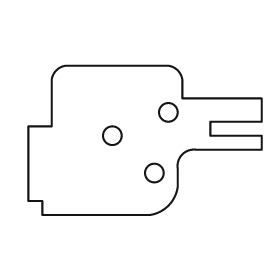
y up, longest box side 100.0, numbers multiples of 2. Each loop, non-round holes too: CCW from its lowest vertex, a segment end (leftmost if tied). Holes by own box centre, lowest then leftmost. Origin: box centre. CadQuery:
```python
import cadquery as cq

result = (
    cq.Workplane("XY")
    .moveTo(-44.0, -32.0)
    .lineTo(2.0, -32.0)
    .threePointArc((10.0, -28.0), (14.0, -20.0))
    .lineTo(14.0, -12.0)
    .threePointArc((16.0, -6.0), (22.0, -4.0))
    .lineTo(50.0, -4.0)
    .lineTo(50.0, 2.0)
    .lineTo(28.0, 2.0)
    .lineTo(28.0, 8.0)
    .lineTo(50.0, 8.0)
    .lineTo(50.0, 18.0)
    .lineTo(16.0, 18.0)
    .lineTo(16.0, 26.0)
    .threePointArc((14.0, 30.0), (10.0, 32.0))
    .lineTo(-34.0, 32.0)
    .threePointArc((-38.0, 30.0), (-40.0, 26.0))
    .lineTo(-40.0, 6.0)
    .lineTo(-50.0, 6.0)
    .lineTo(-50.0, -26.0)
    .lineTo(-44.0, -26.0)
    .close()
    .moveTo(4.0, -14.0)
    .circle(4.0)
    .moveTo(-14.0, 2.0)
    .circle(4.0)
    .moveTo(10.0, 12.0)
    .circle(4.0)
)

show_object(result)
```